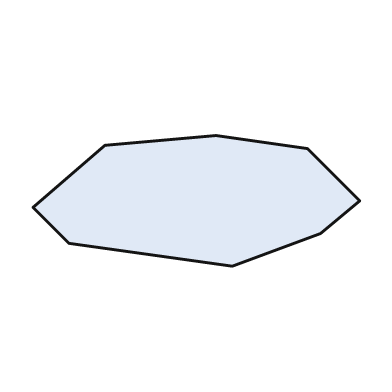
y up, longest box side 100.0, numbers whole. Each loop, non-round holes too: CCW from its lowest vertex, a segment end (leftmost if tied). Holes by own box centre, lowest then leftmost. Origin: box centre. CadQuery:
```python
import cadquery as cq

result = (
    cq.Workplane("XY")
    .moveTo(11.0, -20.0)
    .lineTo(38.0, -10.0)
    .lineTo(50.0, 0.0)
    .lineTo(34.0, 16.0)
    .lineTo(6.0, 20.0)
    .lineTo(-28.0, 17.0)
    .lineTo(-50.0, -2.0)
    .lineTo(-39.0, -13.0)
    .close()
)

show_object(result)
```